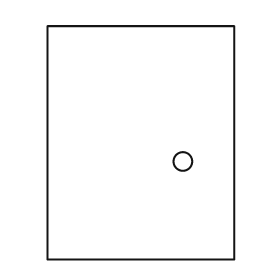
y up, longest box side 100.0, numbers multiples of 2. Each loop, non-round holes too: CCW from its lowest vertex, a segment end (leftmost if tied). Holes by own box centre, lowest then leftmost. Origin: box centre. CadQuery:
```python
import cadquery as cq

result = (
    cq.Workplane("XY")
    .moveTo(-40.0, -50.0)
    .lineTo(40.0, -50.0)
    .lineTo(40.0, 50.0)
    .lineTo(-40.0, 50.0)
    .close()
    .moveTo(18.0, -8.0)
    .circle(4.0)
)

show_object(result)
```